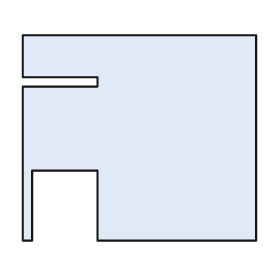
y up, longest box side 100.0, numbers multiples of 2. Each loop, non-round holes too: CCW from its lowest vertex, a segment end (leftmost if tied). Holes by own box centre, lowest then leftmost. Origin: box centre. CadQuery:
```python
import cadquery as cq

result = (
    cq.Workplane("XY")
    .moveTo(-50.0, -44.0)
    .lineTo(-46.0, -44.0)
    .lineTo(-46.0, -14.0)
    .lineTo(-18.0, -14.0)
    .lineTo(-18.0, -44.0)
    .lineTo(50.0, -44.0)
    .lineTo(50.0, 44.0)
    .lineTo(-50.0, 44.0)
    .lineTo(-50.0, 26.0)
    .lineTo(-18.0, 26.0)
    .lineTo(-18.0, 22.0)
    .lineTo(-50.0, 22.0)
    .close()
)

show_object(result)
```